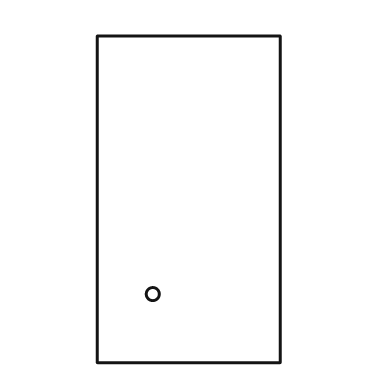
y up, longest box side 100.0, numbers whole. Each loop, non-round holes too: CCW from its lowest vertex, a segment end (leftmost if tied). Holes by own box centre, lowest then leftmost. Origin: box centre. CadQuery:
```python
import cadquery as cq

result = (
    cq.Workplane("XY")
    .moveTo(-28.0, -50.0)
    .lineTo(28.0, -50.0)
    .lineTo(28.0, 50.0)
    .lineTo(-28.0, 50.0)
    .close()
    .moveTo(-11.0, -29.0)
    .circle(2.0)
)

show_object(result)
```